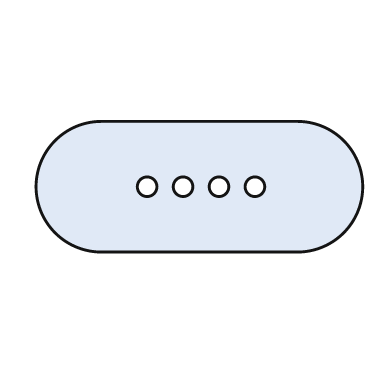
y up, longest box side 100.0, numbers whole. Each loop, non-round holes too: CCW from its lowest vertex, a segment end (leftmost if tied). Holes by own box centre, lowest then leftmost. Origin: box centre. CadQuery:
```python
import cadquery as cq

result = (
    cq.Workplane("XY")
    .moveTo(-30.0, -20.0)
    .lineTo(30.0, -20.0)
    .threePointArc((50.0, 0.0), (30.0, 20.0))
    .lineTo(-30.0, 20.0)
    .threePointArc((-50.0, 0.0), (-30.0, -20.0))
    .close()
    .moveTo(-16.0, 0.0)
    .circle(3.0)
    .moveTo(-5.0, 0.0)
    .circle(3.0)
    .moveTo(6.0, 0.0)
    .circle(3.0)
    .moveTo(17.0, 0.0)
    .circle(3.0)
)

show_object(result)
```